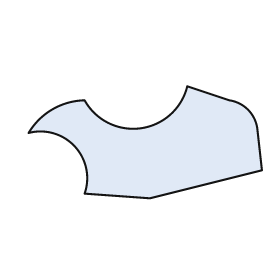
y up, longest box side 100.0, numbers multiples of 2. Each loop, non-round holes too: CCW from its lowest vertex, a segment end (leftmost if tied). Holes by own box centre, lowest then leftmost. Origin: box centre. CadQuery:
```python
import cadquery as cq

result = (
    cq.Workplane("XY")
    .moveTo(2.0, -24.0)
    .lineTo(50.0, -12.0)
    .lineTo(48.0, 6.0)
    .threePointArc((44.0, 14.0), (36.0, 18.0))
    .lineTo(18.0, 24.0)
    .threePointArc((-2.0, 6.0), (-26.0, 18.0))
    .threePointArc((-40.0, 14.0), (-50.0, 4.0))
    .threePointArc((-30.0, -2.0), (-26.0, -22.0))
    .close()
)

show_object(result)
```